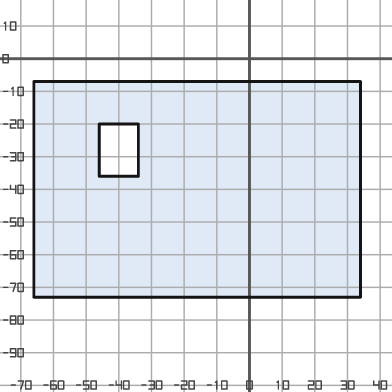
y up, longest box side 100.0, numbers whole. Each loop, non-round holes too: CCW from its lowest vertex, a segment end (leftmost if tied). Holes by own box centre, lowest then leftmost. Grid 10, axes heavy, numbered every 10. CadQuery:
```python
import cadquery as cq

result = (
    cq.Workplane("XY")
    .moveTo(-66.0, -73.0)
    .lineTo(34.0, -73.0)
    .lineTo(34.0, -7.0)
    .lineTo(-66.0, -7.0)
    .close()
    .moveTo(-46.0, -36.0)
    .lineTo(-34.0, -36.0)
    .lineTo(-34.0, -20.0)
    .lineTo(-46.0, -20.0)
    .close()
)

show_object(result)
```